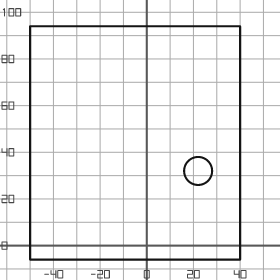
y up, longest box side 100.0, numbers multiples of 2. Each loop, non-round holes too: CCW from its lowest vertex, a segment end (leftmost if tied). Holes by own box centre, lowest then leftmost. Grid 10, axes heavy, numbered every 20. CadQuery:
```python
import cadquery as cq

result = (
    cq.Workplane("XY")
    .moveTo(-50.0, -6.0)
    .lineTo(40.0, -6.0)
    .lineTo(40.0, 94.0)
    .lineTo(-50.0, 94.0)
    .close()
    .moveTo(22.0, 32.0)
    .circle(6.0)
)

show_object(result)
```